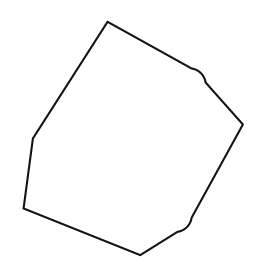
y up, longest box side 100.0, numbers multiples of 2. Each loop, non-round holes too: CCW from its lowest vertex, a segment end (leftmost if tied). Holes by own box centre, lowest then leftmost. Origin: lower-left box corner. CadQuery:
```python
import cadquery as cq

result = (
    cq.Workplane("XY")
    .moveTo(50.0, 0.0)
    .lineTo(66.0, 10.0)
    .threePointArc((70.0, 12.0), (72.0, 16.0))
    .lineTo(94.0, 56.0)
    .lineTo(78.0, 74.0)
    .threePointArc((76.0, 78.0), (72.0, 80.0))
    .lineTo(36.0, 100.0)
    .lineTo(4.0, 50.0)
    .lineTo(0.0, 20.0)
    .close()
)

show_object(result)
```